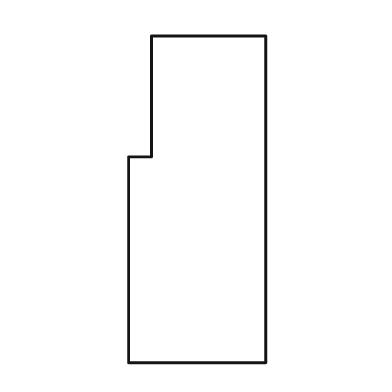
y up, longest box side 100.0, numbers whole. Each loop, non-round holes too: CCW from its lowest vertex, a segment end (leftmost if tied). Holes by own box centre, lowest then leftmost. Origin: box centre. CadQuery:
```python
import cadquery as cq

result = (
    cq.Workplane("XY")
    .moveTo(-21.0, -50.0)
    .lineTo(21.0, -50.0)
    .lineTo(21.0, 50.0)
    .lineTo(-14.0, 50.0)
    .lineTo(-14.0, 13.0)
    .lineTo(-21.0, 13.0)
    .close()
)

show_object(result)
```